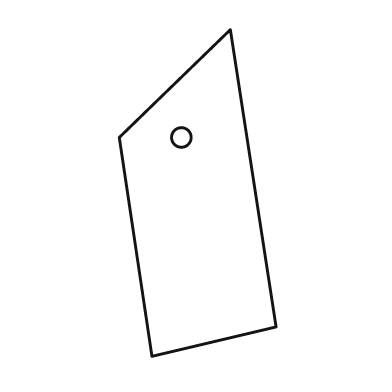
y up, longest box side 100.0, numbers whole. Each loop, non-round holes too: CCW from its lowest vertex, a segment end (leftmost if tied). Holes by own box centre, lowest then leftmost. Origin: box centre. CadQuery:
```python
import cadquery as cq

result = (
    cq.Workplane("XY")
    .moveTo(-14.0, -50.0)
    .lineTo(24.0, -41.0)
    .lineTo(10.0, 50.0)
    .lineTo(-24.0, 17.0)
    .close()
    .moveTo(-5.0, 17.0)
    .circle(3.0)
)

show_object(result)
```